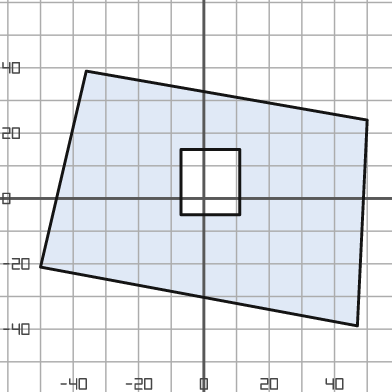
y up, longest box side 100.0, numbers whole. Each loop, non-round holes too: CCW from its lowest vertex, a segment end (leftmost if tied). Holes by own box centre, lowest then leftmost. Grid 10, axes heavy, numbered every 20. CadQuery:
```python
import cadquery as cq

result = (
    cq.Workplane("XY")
    .moveTo(47.0, -39.0)
    .lineTo(50.0, 24.0)
    .lineTo(-36.0, 39.0)
    .lineTo(-50.0, -21.0)
    .close()
    .moveTo(-7.0, -5.0)
    .lineTo(11.0, -5.0)
    .lineTo(11.0, 15.0)
    .lineTo(-7.0, 15.0)
    .close()
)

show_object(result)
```